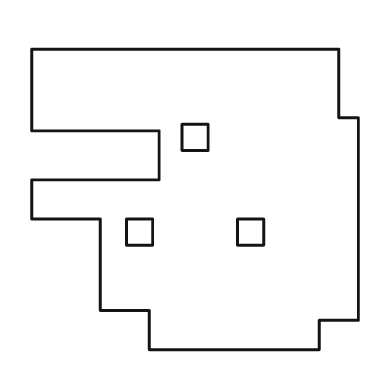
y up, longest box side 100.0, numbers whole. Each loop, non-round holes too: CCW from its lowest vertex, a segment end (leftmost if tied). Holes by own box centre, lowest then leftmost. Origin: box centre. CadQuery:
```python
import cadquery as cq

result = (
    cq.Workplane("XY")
    .moveTo(-14.0, -46.0)
    .lineTo(38.0, -46.0)
    .lineTo(38.0, -37.0)
    .lineTo(50.0, -37.0)
    .lineTo(50.0, 25.0)
    .lineTo(44.0, 25.0)
    .lineTo(44.0, 46.0)
    .lineTo(-50.0, 46.0)
    .lineTo(-50.0, 21.0)
    .lineTo(-11.0, 21.0)
    .lineTo(-11.0, 6.0)
    .lineTo(-50.0, 6.0)
    .lineTo(-50.0, -6.0)
    .lineTo(-29.0, -6.0)
    .lineTo(-29.0, -34.0)
    .lineTo(-14.0, -34.0)
    .close()
    .moveTo(-21.0, -14.0)
    .lineTo(-13.0, -14.0)
    .lineTo(-13.0, -6.0)
    .lineTo(-21.0, -6.0)
    .close()
    .moveTo(13.0, -14.0)
    .lineTo(21.0, -14.0)
    .lineTo(21.0, -6.0)
    .lineTo(13.0, -6.0)
    .close()
    .moveTo(-4.0, 15.0)
    .lineTo(4.0, 15.0)
    .lineTo(4.0, 23.0)
    .lineTo(-4.0, 23.0)
    .close()
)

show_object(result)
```